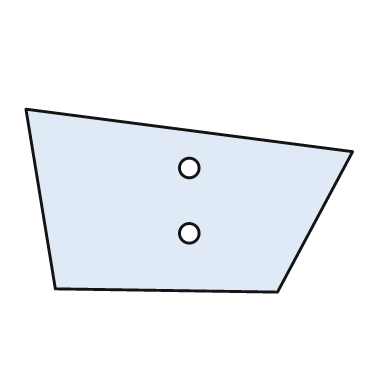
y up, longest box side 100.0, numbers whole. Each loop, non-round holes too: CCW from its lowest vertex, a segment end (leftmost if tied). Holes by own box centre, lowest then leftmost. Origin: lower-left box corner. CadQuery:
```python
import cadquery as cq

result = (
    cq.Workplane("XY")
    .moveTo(77.0, 0.0)
    .lineTo(100.0, 43.0)
    .lineTo(0.0, 56.0)
    .lineTo(9.0, 1.0)
    .close()
    .moveTo(50.0, 18.0)
    .circle(3.0)
    .moveTo(50.0, 38.0)
    .circle(3.0)
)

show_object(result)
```